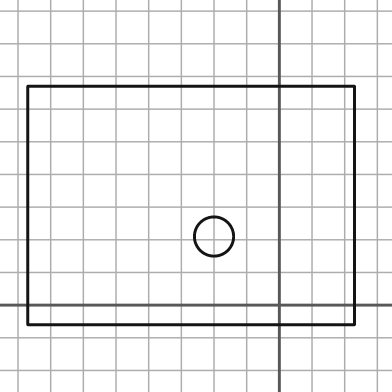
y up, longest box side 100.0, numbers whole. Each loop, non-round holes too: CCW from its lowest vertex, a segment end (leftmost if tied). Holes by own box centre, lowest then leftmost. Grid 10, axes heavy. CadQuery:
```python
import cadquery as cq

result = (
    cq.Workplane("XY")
    .moveTo(-77.0, -6.0)
    .lineTo(23.0, -6.0)
    .lineTo(23.0, 67.0)
    .lineTo(-77.0, 67.0)
    .close()
    .moveTo(-20.0, 21.0)
    .circle(6.0)
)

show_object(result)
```